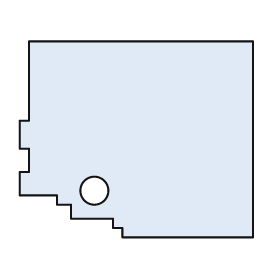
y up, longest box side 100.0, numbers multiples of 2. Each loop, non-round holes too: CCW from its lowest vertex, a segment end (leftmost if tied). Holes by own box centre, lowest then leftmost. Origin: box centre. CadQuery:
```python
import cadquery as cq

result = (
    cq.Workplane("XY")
    .moveTo(-6.0, -42.0)
    .lineTo(50.0, -42.0)
    .lineTo(50.0, 42.0)
    .lineTo(-46.0, 42.0)
    .lineTo(-46.0, 8.0)
    .lineTo(-50.0, 8.0)
    .lineTo(-50.0, -4.0)
    .lineTo(-46.0, -4.0)
    .lineTo(-46.0, -14.0)
    .lineTo(-50.0, -14.0)
    .lineTo(-50.0, -24.0)
    .lineTo(-34.0, -24.0)
    .lineTo(-34.0, -28.0)
    .lineTo(-28.0, -28.0)
    .lineTo(-28.0, -34.0)
    .lineTo(-10.0, -34.0)
    .lineTo(-10.0, -38.0)
    .lineTo(-6.0, -38.0)
    .close()
    .moveTo(-18.0, -22.0)
    .circle(6.0)
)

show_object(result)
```